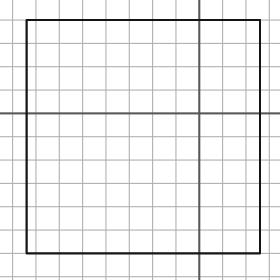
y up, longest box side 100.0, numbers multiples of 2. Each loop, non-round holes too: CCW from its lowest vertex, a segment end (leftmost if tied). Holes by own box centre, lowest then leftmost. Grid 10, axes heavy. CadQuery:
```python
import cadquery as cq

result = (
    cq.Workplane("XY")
    .moveTo(-74.0, -60.0)
    .lineTo(26.0, -60.0)
    .lineTo(26.0, 40.0)
    .lineTo(-74.0, 40.0)
    .close()
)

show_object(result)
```